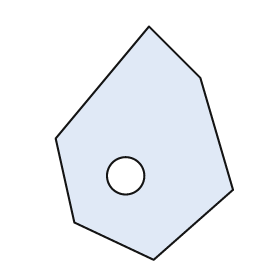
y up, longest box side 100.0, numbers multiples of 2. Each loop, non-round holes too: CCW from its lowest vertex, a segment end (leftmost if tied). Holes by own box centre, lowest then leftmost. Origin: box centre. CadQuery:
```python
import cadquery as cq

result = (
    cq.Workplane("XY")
    .moveTo(4.0, -50.0)
    .lineTo(38.0, -20.0)
    .lineTo(24.0, 28.0)
    .lineTo(2.0, 50.0)
    .lineTo(-38.0, 2.0)
    .lineTo(-30.0, -34.0)
    .close()
    .moveTo(-8.0, -14.0)
    .circle(8.0)
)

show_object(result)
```